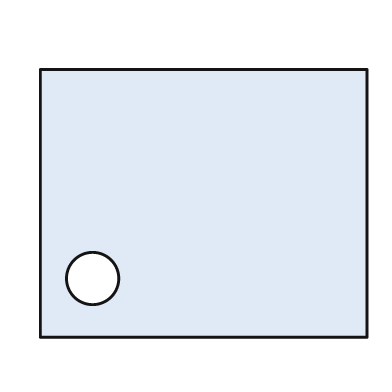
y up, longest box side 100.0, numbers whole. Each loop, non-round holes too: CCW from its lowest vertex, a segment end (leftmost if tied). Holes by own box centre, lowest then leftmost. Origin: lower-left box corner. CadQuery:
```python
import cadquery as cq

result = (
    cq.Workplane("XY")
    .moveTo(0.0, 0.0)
    .lineTo(100.0, 0.0)
    .lineTo(100.0, 82.0)
    .lineTo(0.0, 82.0)
    .close()
    .moveTo(16.0, 18.0)
    .circle(8.0)
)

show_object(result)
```